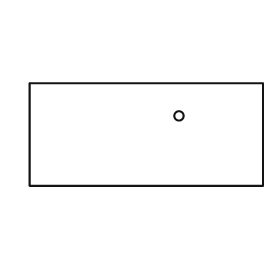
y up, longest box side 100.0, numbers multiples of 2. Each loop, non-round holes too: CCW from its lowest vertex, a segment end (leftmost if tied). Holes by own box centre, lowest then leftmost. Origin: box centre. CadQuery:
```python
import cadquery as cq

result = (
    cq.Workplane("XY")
    .moveTo(-50.0, -22.0)
    .lineTo(50.0, -22.0)
    .lineTo(50.0, 22.0)
    .lineTo(-50.0, 22.0)
    .close()
    .moveTo(14.0, 8.0)
    .circle(2.0)
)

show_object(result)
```